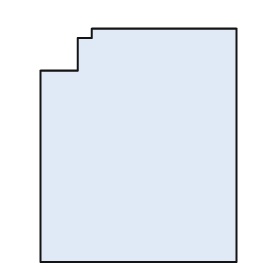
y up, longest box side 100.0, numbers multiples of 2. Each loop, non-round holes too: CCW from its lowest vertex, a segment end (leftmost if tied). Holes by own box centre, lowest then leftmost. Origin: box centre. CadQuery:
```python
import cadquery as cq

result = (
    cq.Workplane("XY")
    .moveTo(-42.0, -50.0)
    .lineTo(42.0, -50.0)
    .lineTo(42.0, 50.0)
    .lineTo(-20.0, 50.0)
    .lineTo(-20.0, 46.0)
    .lineTo(-26.0, 46.0)
    .lineTo(-26.0, 32.0)
    .lineTo(-42.0, 32.0)
    .close()
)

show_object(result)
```